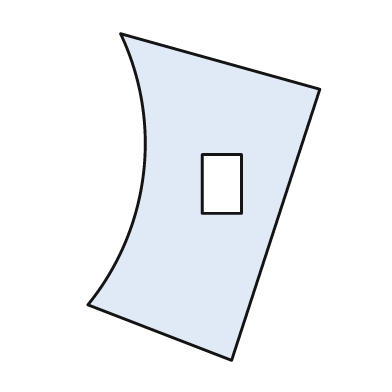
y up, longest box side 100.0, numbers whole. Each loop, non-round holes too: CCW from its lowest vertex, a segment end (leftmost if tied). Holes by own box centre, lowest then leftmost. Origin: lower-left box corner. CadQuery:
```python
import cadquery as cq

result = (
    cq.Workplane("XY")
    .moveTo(44.0, 0.0)
    .lineTo(71.0, 83.0)
    .lineTo(10.0, 100.0)
    .threePointArc((17.0, 57.0), (0.0, 17.0))
    .close()
    .moveTo(35.0, 45.0)
    .lineTo(47.0, 45.0)
    .lineTo(47.0, 63.0)
    .lineTo(35.0, 63.0)
    .close()
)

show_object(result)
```